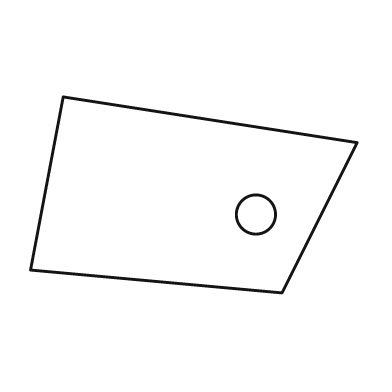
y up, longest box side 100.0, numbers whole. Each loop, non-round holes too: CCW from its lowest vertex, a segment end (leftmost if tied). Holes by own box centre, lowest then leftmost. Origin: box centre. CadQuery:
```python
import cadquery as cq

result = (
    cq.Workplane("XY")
    .moveTo(27.0, -30.0)
    .lineTo(50.0, 16.0)
    .lineTo(-40.0, 30.0)
    .lineTo(-50.0, -23.0)
    .close()
    .moveTo(19.0, -6.0)
    .circle(6.0)
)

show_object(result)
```